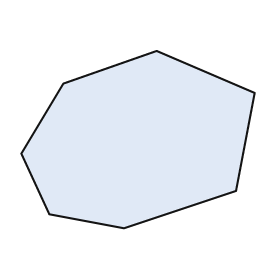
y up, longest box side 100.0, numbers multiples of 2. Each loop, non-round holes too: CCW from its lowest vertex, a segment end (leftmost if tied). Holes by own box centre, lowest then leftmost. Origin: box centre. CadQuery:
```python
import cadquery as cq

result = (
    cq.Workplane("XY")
    .moveTo(-6.0, -38.0)
    .lineTo(42.0, -22.0)
    .lineTo(50.0, 20.0)
    .lineTo(8.0, 38.0)
    .lineTo(-32.0, 24.0)
    .lineTo(-50.0, -6.0)
    .lineTo(-38.0, -32.0)
    .close()
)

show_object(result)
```